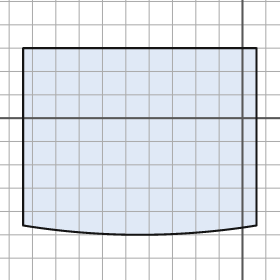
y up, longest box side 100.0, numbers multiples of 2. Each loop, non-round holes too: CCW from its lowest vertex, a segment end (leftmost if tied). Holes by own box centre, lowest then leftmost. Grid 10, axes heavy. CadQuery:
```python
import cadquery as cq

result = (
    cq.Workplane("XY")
    .moveTo(-94.0, -46.0)
    .threePointArc((-44.0, -50.0), (6.0, -46.0))
    .lineTo(6.0, 30.0)
    .lineTo(-94.0, 30.0)
    .close()
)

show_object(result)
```